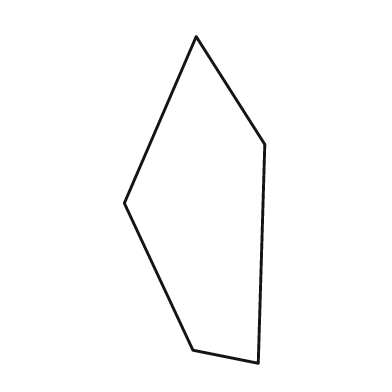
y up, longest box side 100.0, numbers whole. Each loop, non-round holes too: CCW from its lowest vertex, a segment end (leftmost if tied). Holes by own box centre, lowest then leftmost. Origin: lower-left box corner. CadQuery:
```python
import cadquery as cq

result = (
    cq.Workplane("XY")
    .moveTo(41.0, 0.0)
    .lineTo(43.0, 67.0)
    .lineTo(22.0, 100.0)
    .lineTo(0.0, 49.0)
    .lineTo(21.0, 4.0)
    .close()
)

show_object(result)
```